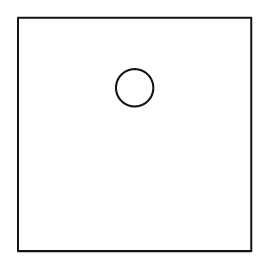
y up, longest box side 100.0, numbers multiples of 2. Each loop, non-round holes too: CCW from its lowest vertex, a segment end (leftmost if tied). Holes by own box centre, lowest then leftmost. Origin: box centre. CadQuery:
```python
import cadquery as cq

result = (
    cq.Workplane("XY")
    .moveTo(-50.0, -50.0)
    .lineTo(50.0, -50.0)
    .lineTo(50.0, 50.0)
    .lineTo(-50.0, 50.0)
    .close()
    .moveTo(0.0, 20.0)
    .circle(8.0)
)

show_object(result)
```